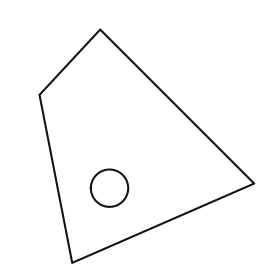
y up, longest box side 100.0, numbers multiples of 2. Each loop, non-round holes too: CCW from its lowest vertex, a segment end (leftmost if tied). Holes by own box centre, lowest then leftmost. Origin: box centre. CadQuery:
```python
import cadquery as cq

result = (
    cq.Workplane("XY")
    .moveTo(-32.0, -50.0)
    .lineTo(46.0, -16.0)
    .lineTo(-20.0, 50.0)
    .lineTo(-46.0, 22.0)
    .close()
    .moveTo(-16.0, -18.0)
    .circle(8.0)
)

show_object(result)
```